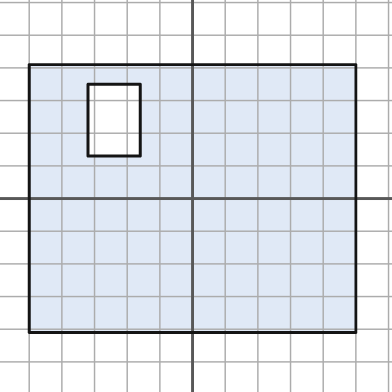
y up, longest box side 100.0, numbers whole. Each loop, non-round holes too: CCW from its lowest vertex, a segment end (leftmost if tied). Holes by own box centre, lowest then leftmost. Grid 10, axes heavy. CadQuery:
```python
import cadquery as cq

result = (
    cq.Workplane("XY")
    .moveTo(-50.0, -41.0)
    .lineTo(50.0, -41.0)
    .lineTo(50.0, 41.0)
    .lineTo(-50.0, 41.0)
    .close()
    .moveTo(-32.0, 13.0)
    .lineTo(-16.0, 13.0)
    .lineTo(-16.0, 35.0)
    .lineTo(-32.0, 35.0)
    .close()
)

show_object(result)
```